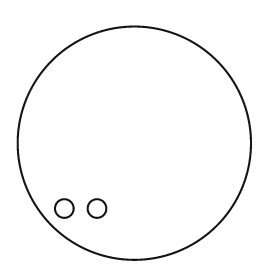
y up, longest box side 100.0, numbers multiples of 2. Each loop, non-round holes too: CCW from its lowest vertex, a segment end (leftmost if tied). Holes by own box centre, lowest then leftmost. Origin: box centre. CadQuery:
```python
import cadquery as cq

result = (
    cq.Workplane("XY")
    .moveTo(0.0, 0.0)
    .circle(50.0)
    .moveTo(-30.0, -28.0)
    .circle(4.0)
    .moveTo(-16.0, -28.0)
    .circle(4.0)
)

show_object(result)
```